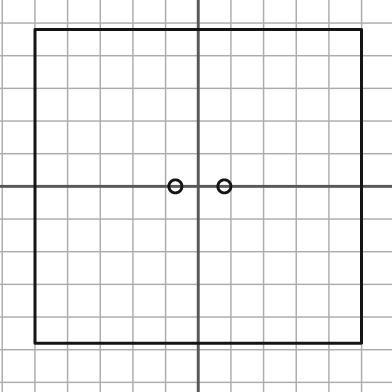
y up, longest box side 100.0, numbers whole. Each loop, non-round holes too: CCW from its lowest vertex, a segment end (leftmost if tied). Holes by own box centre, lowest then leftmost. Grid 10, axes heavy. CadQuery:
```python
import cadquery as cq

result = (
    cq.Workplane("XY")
    .moveTo(-50.0, -48.0)
    .lineTo(50.0, -48.0)
    .lineTo(50.0, 48.0)
    .lineTo(-50.0, 48.0)
    .close()
    .moveTo(-7.0, 0.0)
    .circle(2.0)
    .moveTo(8.0, 0.0)
    .circle(2.0)
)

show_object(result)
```